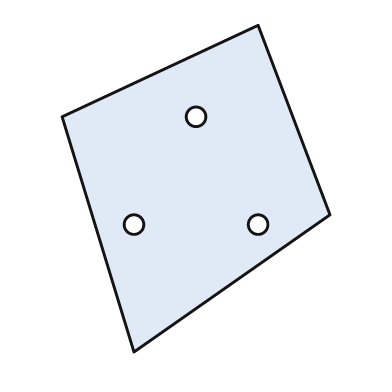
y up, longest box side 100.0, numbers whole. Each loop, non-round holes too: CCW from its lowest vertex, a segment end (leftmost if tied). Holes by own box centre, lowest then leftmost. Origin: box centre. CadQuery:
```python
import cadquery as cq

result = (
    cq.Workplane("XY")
    .moveTo(-19.0, -50.0)
    .lineTo(41.0, -8.0)
    .lineTo(19.0, 50.0)
    .lineTo(-41.0, 22.0)
    .close()
    .moveTo(-19.0, -11.0)
    .circle(3.0)
    .moveTo(19.0, -11.0)
    .circle(3.0)
    .moveTo(0.0, 22.0)
    .circle(3.0)
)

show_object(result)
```